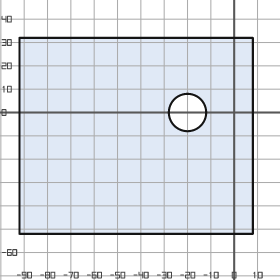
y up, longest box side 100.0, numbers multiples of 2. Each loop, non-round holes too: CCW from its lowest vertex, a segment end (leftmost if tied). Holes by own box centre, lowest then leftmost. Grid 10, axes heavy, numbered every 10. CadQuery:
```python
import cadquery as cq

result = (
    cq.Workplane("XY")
    .moveTo(-92.0, -52.0)
    .lineTo(8.0, -52.0)
    .lineTo(8.0, 32.0)
    .lineTo(-92.0, 32.0)
    .close()
    .moveTo(-20.0, 0.0)
    .circle(8.0)
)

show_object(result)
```